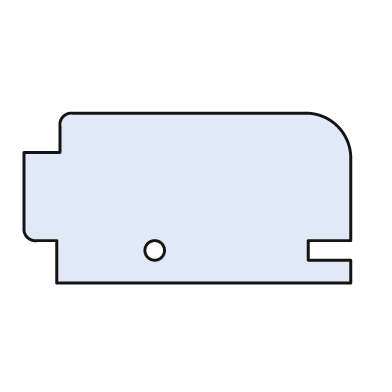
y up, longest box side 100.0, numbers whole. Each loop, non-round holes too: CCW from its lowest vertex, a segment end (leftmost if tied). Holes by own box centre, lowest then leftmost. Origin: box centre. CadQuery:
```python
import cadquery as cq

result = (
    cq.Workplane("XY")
    .moveTo(-40.0, -26.0)
    .lineTo(50.0, -26.0)
    .lineTo(50.0, -19.0)
    .lineTo(37.0, -19.0)
    .lineTo(37.0, -13.0)
    .lineTo(50.0, -13.0)
    .lineTo(50.0, 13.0)
    .threePointArc((46.0, 22.0), (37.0, 26.0))
    .lineTo(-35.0, 26.0)
    .threePointArc((-38.0, 25.0), (-39.0, 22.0))
    .lineTo(-39.0, 14.0)
    .lineTo(-50.0, 14.0)
    .lineTo(-50.0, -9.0)
    .threePointArc((-49.0, -12.0), (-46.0, -13.0))
    .lineTo(-40.0, -13.0)
    .close()
    .moveTo(-10.0, -16.0)
    .circle(3.0)
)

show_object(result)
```